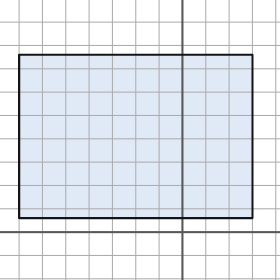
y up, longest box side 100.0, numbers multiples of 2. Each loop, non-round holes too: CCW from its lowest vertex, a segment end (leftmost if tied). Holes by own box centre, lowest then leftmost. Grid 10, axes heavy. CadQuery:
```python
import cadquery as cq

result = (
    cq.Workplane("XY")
    .moveTo(-70.0, 6.0)
    .lineTo(30.0, 6.0)
    .lineTo(30.0, 76.0)
    .lineTo(-70.0, 76.0)
    .close()
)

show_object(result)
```